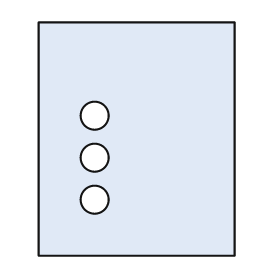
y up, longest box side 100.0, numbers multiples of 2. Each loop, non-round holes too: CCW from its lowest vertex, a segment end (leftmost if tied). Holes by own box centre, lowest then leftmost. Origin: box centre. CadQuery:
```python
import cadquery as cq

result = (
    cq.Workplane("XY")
    .moveTo(-42.0, -50.0)
    .lineTo(42.0, -50.0)
    .lineTo(42.0, 50.0)
    .lineTo(-42.0, 50.0)
    .close()
    .moveTo(-18.0, -26.0)
    .circle(6.0)
    .moveTo(-18.0, -8.0)
    .circle(6.0)
    .moveTo(-18.0, 10.0)
    .circle(6.0)
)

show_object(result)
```